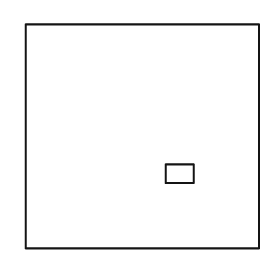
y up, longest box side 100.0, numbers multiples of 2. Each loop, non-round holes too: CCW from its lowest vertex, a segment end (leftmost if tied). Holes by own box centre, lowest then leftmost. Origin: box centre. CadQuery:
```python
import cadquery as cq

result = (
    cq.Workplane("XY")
    .moveTo(-50.0, -48.0)
    .lineTo(50.0, -48.0)
    .lineTo(50.0, 48.0)
    .lineTo(-50.0, 48.0)
    .close()
    .moveTo(10.0, -20.0)
    .lineTo(22.0, -20.0)
    .lineTo(22.0, -12.0)
    .lineTo(10.0, -12.0)
    .close()
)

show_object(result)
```